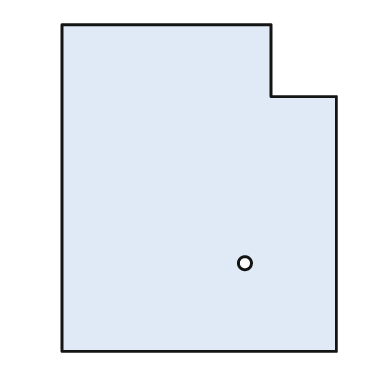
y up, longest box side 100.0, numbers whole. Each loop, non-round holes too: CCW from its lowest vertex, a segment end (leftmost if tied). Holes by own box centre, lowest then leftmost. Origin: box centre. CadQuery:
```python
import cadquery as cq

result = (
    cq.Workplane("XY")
    .moveTo(-42.0, -50.0)
    .lineTo(42.0, -50.0)
    .lineTo(42.0, 28.0)
    .lineTo(22.0, 28.0)
    .lineTo(22.0, 50.0)
    .lineTo(-42.0, 50.0)
    .close()
    .moveTo(14.0, -23.0)
    .circle(2.0)
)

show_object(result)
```